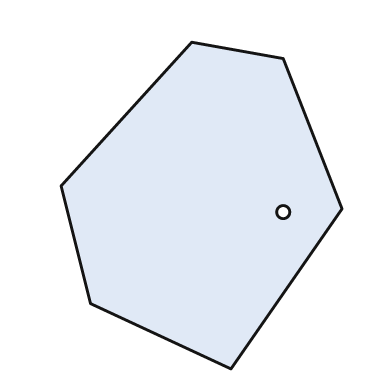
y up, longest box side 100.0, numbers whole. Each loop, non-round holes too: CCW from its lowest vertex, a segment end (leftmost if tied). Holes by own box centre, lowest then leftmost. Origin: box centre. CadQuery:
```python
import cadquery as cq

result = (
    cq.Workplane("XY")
    .moveTo(9.0, -50.0)
    .lineTo(43.0, -1.0)
    .lineTo(25.0, 45.0)
    .lineTo(-3.0, 50.0)
    .lineTo(-43.0, 6.0)
    .lineTo(-34.0, -30.0)
    .close()
    .moveTo(25.0, -2.0)
    .circle(2.0)
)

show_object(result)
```